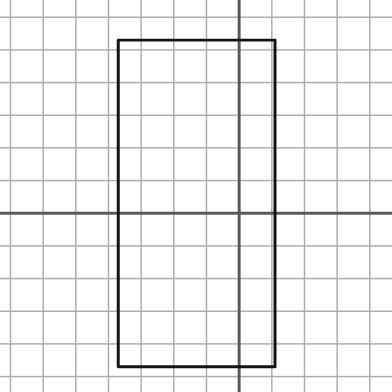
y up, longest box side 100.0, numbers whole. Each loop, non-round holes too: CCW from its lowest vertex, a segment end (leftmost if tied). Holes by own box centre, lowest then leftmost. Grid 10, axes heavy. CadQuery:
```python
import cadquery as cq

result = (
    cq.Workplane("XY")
    .moveTo(-37.0, -47.0)
    .lineTo(11.0, -47.0)
    .lineTo(11.0, 53.0)
    .lineTo(-37.0, 53.0)
    .close()
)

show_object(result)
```